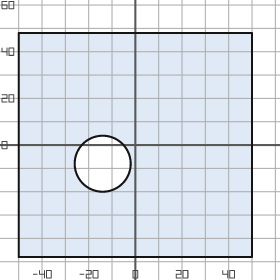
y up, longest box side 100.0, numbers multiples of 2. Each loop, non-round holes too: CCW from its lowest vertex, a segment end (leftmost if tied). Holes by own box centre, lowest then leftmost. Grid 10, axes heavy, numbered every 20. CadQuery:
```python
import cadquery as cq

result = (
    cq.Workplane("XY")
    .moveTo(-50.0, -48.0)
    .lineTo(50.0, -48.0)
    .lineTo(50.0, 48.0)
    .lineTo(-50.0, 48.0)
    .close()
    .moveTo(-14.0, -8.0)
    .circle(12.0)
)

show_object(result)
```